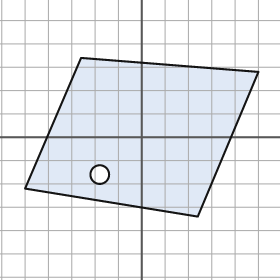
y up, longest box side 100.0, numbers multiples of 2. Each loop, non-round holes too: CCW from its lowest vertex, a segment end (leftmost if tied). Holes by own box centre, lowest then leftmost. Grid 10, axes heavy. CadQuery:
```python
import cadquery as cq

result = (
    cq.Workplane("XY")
    .moveTo(24.0, -34.0)
    .lineTo(50.0, 28.0)
    .lineTo(-26.0, 34.0)
    .lineTo(-50.0, -22.0)
    .close()
    .moveTo(-18.0, -16.0)
    .circle(4.0)
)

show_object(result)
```